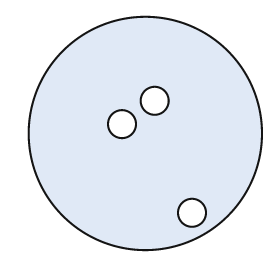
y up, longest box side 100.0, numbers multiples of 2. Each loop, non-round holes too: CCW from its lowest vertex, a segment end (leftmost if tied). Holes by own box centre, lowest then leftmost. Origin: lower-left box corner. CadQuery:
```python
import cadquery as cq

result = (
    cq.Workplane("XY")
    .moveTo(50.0, 50.0)
    .circle(50.0)
    .moveTo(70.0, 16.0)
    .circle(6.0)
    .moveTo(40.0, 54.0)
    .circle(6.0)
    .moveTo(54.0, 64.0)
    .circle(6.0)
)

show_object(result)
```